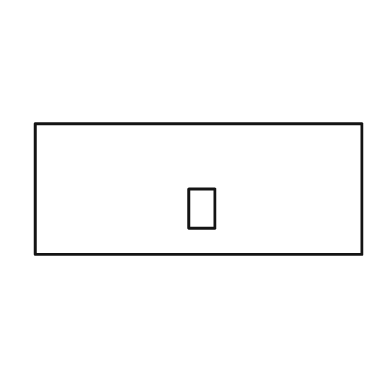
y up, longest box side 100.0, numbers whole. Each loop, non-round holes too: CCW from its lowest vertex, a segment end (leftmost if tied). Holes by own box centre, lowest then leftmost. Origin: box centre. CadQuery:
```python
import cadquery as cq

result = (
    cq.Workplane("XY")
    .moveTo(-50.0, -20.0)
    .lineTo(50.0, -20.0)
    .lineTo(50.0, 20.0)
    .lineTo(-50.0, 20.0)
    .close()
    .moveTo(-3.0, -12.0)
    .lineTo(5.0, -12.0)
    .lineTo(5.0, 0.0)
    .lineTo(-3.0, 0.0)
    .close()
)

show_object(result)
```